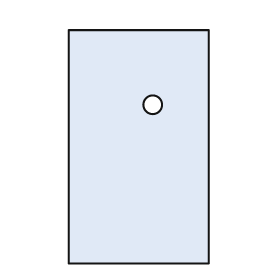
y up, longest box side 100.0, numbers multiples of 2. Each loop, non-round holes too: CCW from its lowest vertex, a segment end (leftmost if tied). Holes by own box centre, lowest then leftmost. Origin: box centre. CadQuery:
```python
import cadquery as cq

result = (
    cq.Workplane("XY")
    .moveTo(-30.0, -50.0)
    .lineTo(30.0, -50.0)
    .lineTo(30.0, 50.0)
    .lineTo(-30.0, 50.0)
    .close()
    .moveTo(6.0, 18.0)
    .circle(4.0)
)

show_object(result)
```